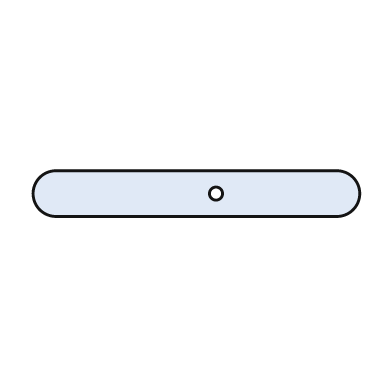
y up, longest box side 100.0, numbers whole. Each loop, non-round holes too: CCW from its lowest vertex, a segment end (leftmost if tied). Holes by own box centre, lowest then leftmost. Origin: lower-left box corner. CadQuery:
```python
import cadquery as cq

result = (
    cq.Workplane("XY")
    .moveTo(7.0, 0.0)
    .lineTo(93.0, 0.0)
    .threePointArc((100.0, 7.0), (93.0, 14.0))
    .lineTo(7.0, 14.0)
    .threePointArc((0.0, 7.0), (7.0, 0.0))
    .close()
    .moveTo(56.0, 7.0)
    .circle(2.0)
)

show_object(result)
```